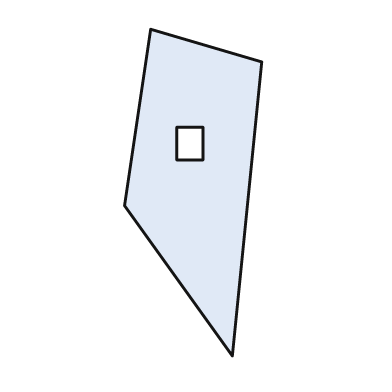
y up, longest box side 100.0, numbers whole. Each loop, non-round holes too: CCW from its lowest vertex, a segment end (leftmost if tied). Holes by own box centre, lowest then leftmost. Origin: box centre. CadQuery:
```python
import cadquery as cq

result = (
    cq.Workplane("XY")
    .moveTo(12.0, -50.0)
    .lineTo(21.0, 40.0)
    .lineTo(-13.0, 50.0)
    .lineTo(-21.0, -4.0)
    .close()
    .moveTo(-5.0, 10.0)
    .lineTo(3.0, 10.0)
    .lineTo(3.0, 20.0)
    .lineTo(-5.0, 20.0)
    .close()
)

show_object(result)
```